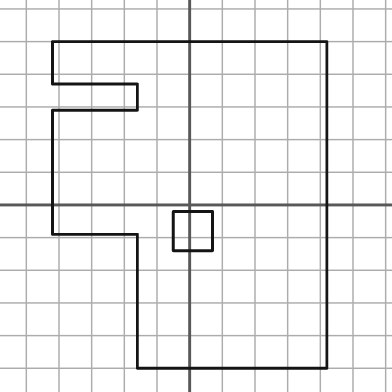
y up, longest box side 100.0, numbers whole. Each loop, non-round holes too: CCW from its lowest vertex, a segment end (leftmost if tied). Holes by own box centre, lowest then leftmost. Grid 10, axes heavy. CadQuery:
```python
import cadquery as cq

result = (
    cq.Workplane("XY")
    .moveTo(-16.0, -50.0)
    .lineTo(42.0, -50.0)
    .lineTo(42.0, 50.0)
    .lineTo(-42.0, 50.0)
    .lineTo(-42.0, 37.0)
    .lineTo(-16.0, 37.0)
    .lineTo(-16.0, 29.0)
    .lineTo(-42.0, 29.0)
    .lineTo(-42.0, -9.0)
    .lineTo(-16.0, -9.0)
    .close()
    .moveTo(-5.0, -14.0)
    .lineTo(7.0, -14.0)
    .lineTo(7.0, -2.0)
    .lineTo(-5.0, -2.0)
    .close()
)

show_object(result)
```